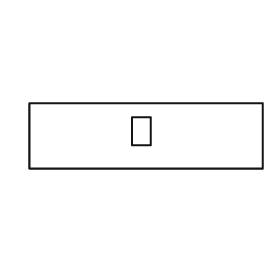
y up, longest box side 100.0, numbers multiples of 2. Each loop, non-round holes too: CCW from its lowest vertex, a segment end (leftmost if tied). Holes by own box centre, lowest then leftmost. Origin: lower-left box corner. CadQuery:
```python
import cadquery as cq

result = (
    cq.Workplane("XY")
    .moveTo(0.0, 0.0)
    .lineTo(100.0, 0.0)
    .lineTo(100.0, 28.0)
    .lineTo(0.0, 28.0)
    .close()
    .moveTo(44.0, 10.0)
    .lineTo(52.0, 10.0)
    .lineTo(52.0, 22.0)
    .lineTo(44.0, 22.0)
    .close()
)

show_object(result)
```